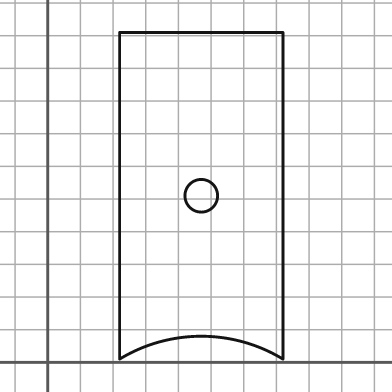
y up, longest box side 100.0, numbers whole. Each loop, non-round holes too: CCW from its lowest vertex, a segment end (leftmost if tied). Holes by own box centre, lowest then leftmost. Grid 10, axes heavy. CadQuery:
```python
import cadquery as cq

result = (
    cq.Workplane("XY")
    .moveTo(22.0, 1.0)
    .threePointArc((47.0, 8.0), (72.0, 1.0))
    .lineTo(72.0, 101.0)
    .lineTo(22.0, 101.0)
    .close()
    .moveTo(47.0, 51.0)
    .circle(5.0)
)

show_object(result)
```